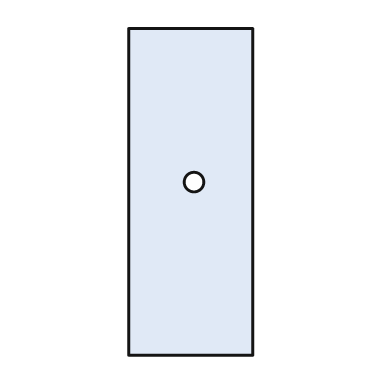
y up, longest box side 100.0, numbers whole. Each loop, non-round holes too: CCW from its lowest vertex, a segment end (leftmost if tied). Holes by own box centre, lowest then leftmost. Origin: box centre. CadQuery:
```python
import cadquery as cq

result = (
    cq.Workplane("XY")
    .moveTo(-19.0, -50.0)
    .lineTo(19.0, -50.0)
    .lineTo(19.0, 50.0)
    .lineTo(-19.0, 50.0)
    .close()
    .moveTo(1.0, 3.0)
    .circle(3.0)
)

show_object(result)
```